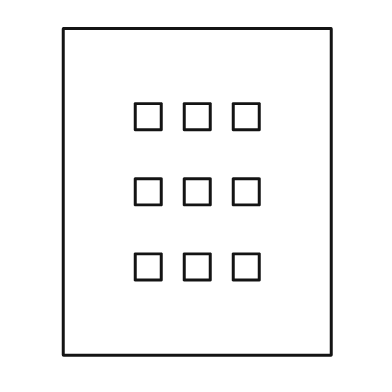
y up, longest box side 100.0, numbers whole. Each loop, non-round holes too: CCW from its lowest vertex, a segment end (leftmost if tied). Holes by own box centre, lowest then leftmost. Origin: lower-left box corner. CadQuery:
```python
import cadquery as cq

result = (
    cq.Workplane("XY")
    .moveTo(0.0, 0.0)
    .lineTo(82.0, 0.0)
    .lineTo(82.0, 100.0)
    .lineTo(0.0, 100.0)
    .close()
    .moveTo(22.0, 23.0)
    .lineTo(30.0, 23.0)
    .lineTo(30.0, 31.0)
    .lineTo(22.0, 31.0)
    .close()
    .moveTo(37.0, 23.0)
    .lineTo(45.0, 23.0)
    .lineTo(45.0, 31.0)
    .lineTo(37.0, 31.0)
    .close()
    .moveTo(52.0, 23.0)
    .lineTo(60.0, 23.0)
    .lineTo(60.0, 31.0)
    .lineTo(52.0, 31.0)
    .close()
    .moveTo(22.0, 46.0)
    .lineTo(30.0, 46.0)
    .lineTo(30.0, 54.0)
    .lineTo(22.0, 54.0)
    .close()
    .moveTo(37.0, 46.0)
    .lineTo(45.0, 46.0)
    .lineTo(45.0, 54.0)
    .lineTo(37.0, 54.0)
    .close()
    .moveTo(52.0, 46.0)
    .lineTo(60.0, 46.0)
    .lineTo(60.0, 54.0)
    .lineTo(52.0, 54.0)
    .close()
    .moveTo(22.0, 69.0)
    .lineTo(30.0, 69.0)
    .lineTo(30.0, 77.0)
    .lineTo(22.0, 77.0)
    .close()
    .moveTo(37.0, 69.0)
    .lineTo(45.0, 69.0)
    .lineTo(45.0, 77.0)
    .lineTo(37.0, 77.0)
    .close()
    .moveTo(52.0, 69.0)
    .lineTo(60.0, 69.0)
    .lineTo(60.0, 77.0)
    .lineTo(52.0, 77.0)
    .close()
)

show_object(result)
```